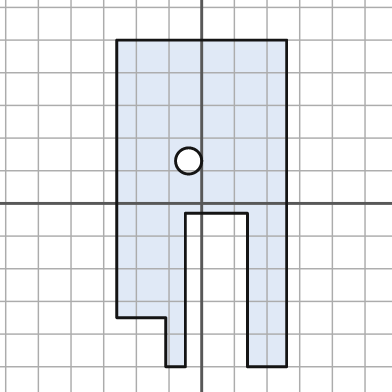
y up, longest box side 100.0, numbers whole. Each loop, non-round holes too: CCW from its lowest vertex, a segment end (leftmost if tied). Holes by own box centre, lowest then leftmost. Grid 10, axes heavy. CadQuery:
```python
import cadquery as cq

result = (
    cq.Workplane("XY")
    .moveTo(-11.0, -50.0)
    .lineTo(-5.0, -50.0)
    .lineTo(-5.0, -3.0)
    .lineTo(14.0, -3.0)
    .lineTo(14.0, -50.0)
    .lineTo(26.0, -50.0)
    .lineTo(26.0, 50.0)
    .lineTo(-26.0, 50.0)
    .lineTo(-26.0, -35.0)
    .lineTo(-11.0, -35.0)
    .close()
    .moveTo(-4.0, 13.0)
    .circle(4.0)
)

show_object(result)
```